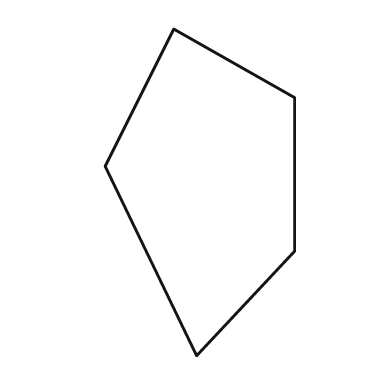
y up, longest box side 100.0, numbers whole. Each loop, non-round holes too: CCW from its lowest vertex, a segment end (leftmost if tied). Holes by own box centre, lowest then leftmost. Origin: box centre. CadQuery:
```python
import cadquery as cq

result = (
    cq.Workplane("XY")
    .moveTo(-1.0, -50.0)
    .lineTo(29.0, -18.0)
    .lineTo(29.0, 29.0)
    .lineTo(-8.0, 50.0)
    .lineTo(-29.0, 8.0)
    .close()
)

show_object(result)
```